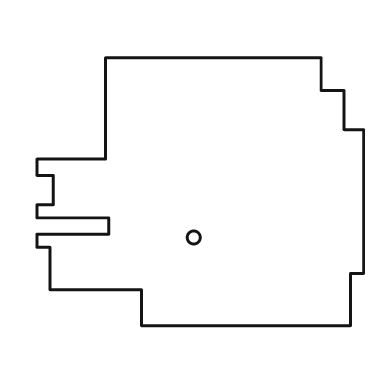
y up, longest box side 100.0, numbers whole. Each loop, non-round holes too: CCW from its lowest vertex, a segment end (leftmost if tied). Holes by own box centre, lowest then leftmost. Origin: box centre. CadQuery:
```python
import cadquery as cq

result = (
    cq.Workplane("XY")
    .moveTo(-18.0, -41.0)
    .lineTo(46.0, -41.0)
    .lineTo(46.0, -25.0)
    .lineTo(50.0, -25.0)
    .lineTo(50.0, 19.0)
    .lineTo(44.0, 19.0)
    .lineTo(44.0, 31.0)
    .lineTo(37.0, 31.0)
    .lineTo(37.0, 41.0)
    .lineTo(-29.0, 41.0)
    .lineTo(-29.0, 10.0)
    .lineTo(-50.0, 10.0)
    .lineTo(-50.0, 5.0)
    .lineTo(-45.0, 5.0)
    .lineTo(-45.0, -4.0)
    .lineTo(-50.0, -4.0)
    .lineTo(-50.0, -8.0)
    .lineTo(-28.0, -8.0)
    .lineTo(-28.0, -13.0)
    .lineTo(-50.0, -13.0)
    .lineTo(-50.0, -17.0)
    .lineTo(-46.0, -17.0)
    .lineTo(-46.0, -30.0)
    .lineTo(-18.0, -30.0)
    .close()
    .moveTo(-2.0, -14.0)
    .circle(2.0)
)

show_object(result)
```